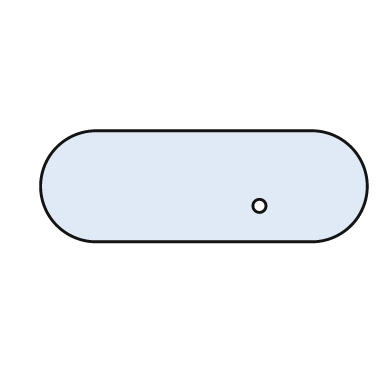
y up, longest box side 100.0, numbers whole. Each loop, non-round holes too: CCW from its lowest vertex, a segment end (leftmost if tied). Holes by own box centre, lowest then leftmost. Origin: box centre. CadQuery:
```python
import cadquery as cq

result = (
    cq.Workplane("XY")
    .moveTo(-33.0, -17.0)
    .lineTo(33.0, -17.0)
    .threePointArc((50.0, 0.0), (33.0, 17.0))
    .lineTo(-33.0, 17.0)
    .threePointArc((-50.0, 0.0), (-33.0, -17.0))
    .close()
    .moveTo(17.0, -6.0)
    .circle(2.0)
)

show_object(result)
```